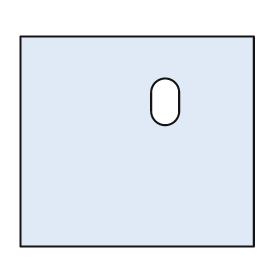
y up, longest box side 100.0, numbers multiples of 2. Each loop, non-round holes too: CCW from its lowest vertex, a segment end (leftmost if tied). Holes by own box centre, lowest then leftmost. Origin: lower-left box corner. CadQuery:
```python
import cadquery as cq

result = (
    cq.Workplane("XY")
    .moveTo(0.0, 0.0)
    .lineTo(100.0, 0.0)
    .lineTo(100.0, 90.0)
    .lineTo(0.0, 90.0)
    .close()
    .moveTo(56.0, 58.0)
    .threePointArc((62.0, 52.0), (68.0, 58.0))
    .lineTo(68.0, 66.0)
    .threePointArc((62.0, 72.0), (56.0, 66.0))
    .close()
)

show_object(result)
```